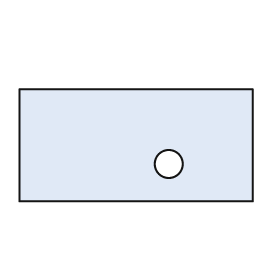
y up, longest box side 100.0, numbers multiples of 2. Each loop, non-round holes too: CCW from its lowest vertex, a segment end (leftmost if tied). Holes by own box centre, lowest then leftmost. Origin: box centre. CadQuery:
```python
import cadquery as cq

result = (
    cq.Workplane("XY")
    .moveTo(-50.0, -24.0)
    .lineTo(50.0, -24.0)
    .lineTo(50.0, 24.0)
    .lineTo(-50.0, 24.0)
    .close()
    .moveTo(14.0, -8.0)
    .circle(6.0)
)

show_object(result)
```